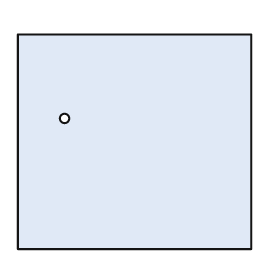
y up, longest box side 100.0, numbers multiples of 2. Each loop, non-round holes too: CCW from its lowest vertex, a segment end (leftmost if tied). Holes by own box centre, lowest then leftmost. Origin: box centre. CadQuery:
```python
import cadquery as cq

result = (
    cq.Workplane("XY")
    .moveTo(-50.0, -46.0)
    .lineTo(50.0, -46.0)
    .lineTo(50.0, 46.0)
    .lineTo(-50.0, 46.0)
    .close()
    .moveTo(-30.0, 10.0)
    .circle(2.0)
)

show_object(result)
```